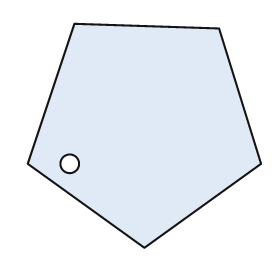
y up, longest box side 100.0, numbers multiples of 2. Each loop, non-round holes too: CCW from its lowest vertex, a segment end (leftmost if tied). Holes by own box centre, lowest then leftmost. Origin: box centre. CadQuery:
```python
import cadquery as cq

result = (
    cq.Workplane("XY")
    .moveTo(0.0, -48.0)
    .lineTo(50.0, -12.0)
    .lineTo(32.0, 46.0)
    .lineTo(-30.0, 48.0)
    .lineTo(-50.0, -12.0)
    .close()
    .moveTo(-32.0, -12.0)
    .circle(4.0)
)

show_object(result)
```